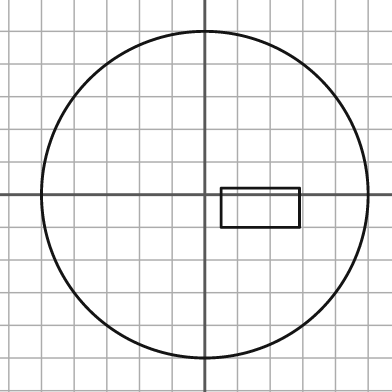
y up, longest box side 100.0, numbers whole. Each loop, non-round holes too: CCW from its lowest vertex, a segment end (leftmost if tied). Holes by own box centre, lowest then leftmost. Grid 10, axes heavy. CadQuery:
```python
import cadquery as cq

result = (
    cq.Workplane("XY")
    .moveTo(0.0, 0.0)
    .circle(50.0)
    .moveTo(5.0, -10.0)
    .lineTo(29.0, -10.0)
    .lineTo(29.0, 2.0)
    .lineTo(5.0, 2.0)
    .close()
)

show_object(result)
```